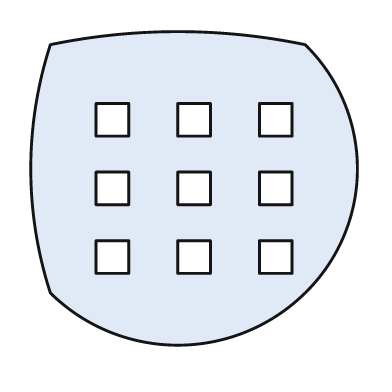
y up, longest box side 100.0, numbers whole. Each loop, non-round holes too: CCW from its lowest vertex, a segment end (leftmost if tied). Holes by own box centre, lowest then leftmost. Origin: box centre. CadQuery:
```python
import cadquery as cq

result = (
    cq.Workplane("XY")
    .moveTo(-44.0, -32.0)
    .threePointArc((-5.0, -48.0), (34.0, -32.0))
    .threePointArc((50.0, 6.0), (34.0, 44.0))
    .threePointArc((-5.0, 48.0), (-44.0, 44.0))
    .threePointArc((-50.0, 6.0), (-44.0, -32.0))
    .close()
    .moveTo(-30.0, -26.0)
    .lineTo(-20.0, -26.0)
    .lineTo(-20.0, -16.0)
    .lineTo(-30.0, -16.0)
    .close()
    .moveTo(-5.0, -26.0)
    .lineTo(5.0, -26.0)
    .lineTo(5.0, -16.0)
    .lineTo(-5.0, -16.0)
    .close()
    .moveTo(20.0, -26.0)
    .lineTo(30.0, -26.0)
    .lineTo(30.0, -16.0)
    .lineTo(20.0, -16.0)
    .close()
    .moveTo(-30.0, -5.0)
    .lineTo(-20.0, -5.0)
    .lineTo(-20.0, 5.0)
    .lineTo(-30.0, 5.0)
    .close()
    .moveTo(-5.0, -5.0)
    .lineTo(5.0, -5.0)
    .lineTo(5.0, 5.0)
    .lineTo(-5.0, 5.0)
    .close()
    .moveTo(20.0, -5.0)
    .lineTo(30.0, -5.0)
    .lineTo(30.0, 5.0)
    .lineTo(20.0, 5.0)
    .close()
    .moveTo(-30.0, 16.0)
    .lineTo(-20.0, 16.0)
    .lineTo(-20.0, 26.0)
    .lineTo(-30.0, 26.0)
    .close()
    .moveTo(-5.0, 16.0)
    .lineTo(5.0, 16.0)
    .lineTo(5.0, 26.0)
    .lineTo(-5.0, 26.0)
    .close()
    .moveTo(20.0, 16.0)
    .lineTo(30.0, 16.0)
    .lineTo(30.0, 26.0)
    .lineTo(20.0, 26.0)
    .close()
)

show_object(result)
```